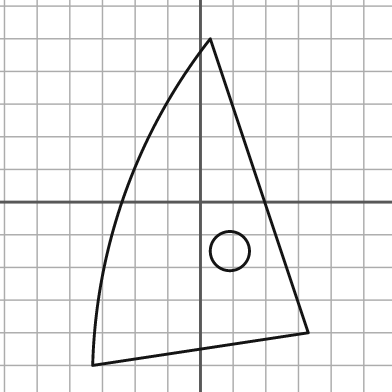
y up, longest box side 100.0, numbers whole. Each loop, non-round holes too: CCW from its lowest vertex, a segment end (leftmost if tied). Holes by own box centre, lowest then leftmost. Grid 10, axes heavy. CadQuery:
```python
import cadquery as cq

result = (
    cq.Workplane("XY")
    .moveTo(-33.0, -50.0)
    .lineTo(33.0, -40.0)
    .lineTo(3.0, 50.0)
    .threePointArc((-23.0, 3.0), (-33.0, -50.0))
    .close()
    .moveTo(9.0, -15.0)
    .circle(6.0)
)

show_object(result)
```